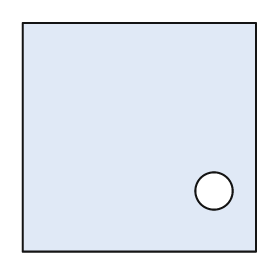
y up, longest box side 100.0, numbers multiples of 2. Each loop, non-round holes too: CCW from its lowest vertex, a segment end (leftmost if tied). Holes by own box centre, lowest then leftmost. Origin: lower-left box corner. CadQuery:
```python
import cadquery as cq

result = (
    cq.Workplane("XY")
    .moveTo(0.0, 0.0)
    .lineTo(100.0, 0.0)
    .lineTo(100.0, 98.0)
    .lineTo(0.0, 98.0)
    .close()
    .moveTo(82.0, 26.0)
    .circle(8.0)
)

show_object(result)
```